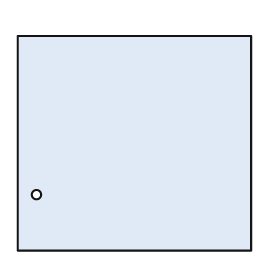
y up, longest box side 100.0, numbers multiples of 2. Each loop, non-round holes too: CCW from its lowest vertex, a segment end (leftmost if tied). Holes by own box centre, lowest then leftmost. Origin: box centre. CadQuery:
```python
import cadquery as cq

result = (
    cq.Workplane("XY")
    .moveTo(-50.0, -46.0)
    .lineTo(50.0, -46.0)
    .lineTo(50.0, 46.0)
    .lineTo(-50.0, 46.0)
    .close()
    .moveTo(-42.0, -22.0)
    .circle(2.0)
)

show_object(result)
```